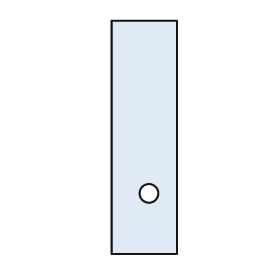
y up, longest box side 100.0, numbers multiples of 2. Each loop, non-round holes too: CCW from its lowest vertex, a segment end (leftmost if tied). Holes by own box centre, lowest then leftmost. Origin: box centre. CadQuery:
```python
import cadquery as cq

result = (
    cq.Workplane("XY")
    .moveTo(-14.0, -50.0)
    .lineTo(14.0, -50.0)
    .lineTo(14.0, 50.0)
    .lineTo(-14.0, 50.0)
    .close()
    .moveTo(2.0, -24.0)
    .circle(4.0)
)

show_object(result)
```